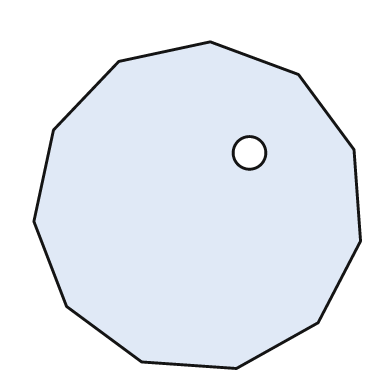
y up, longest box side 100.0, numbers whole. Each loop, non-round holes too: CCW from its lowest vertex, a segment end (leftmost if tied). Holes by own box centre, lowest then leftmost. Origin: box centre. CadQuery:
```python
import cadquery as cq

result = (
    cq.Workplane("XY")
    .moveTo(12.0, -50.0)
    .lineTo(37.0, -36.0)
    .lineTo(50.0, -11.0)
    .lineTo(48.0, 17.0)
    .lineTo(31.0, 40.0)
    .lineTo(4.0, 50.0)
    .lineTo(-24.0, 44.0)
    .lineTo(-44.0, 23.0)
    .lineTo(-50.0, -5.0)
    .lineTo(-40.0, -31.0)
    .lineTo(-17.0, -48.0)
    .close()
    .moveTo(16.0, 16.0)
    .circle(5.0)
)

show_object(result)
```